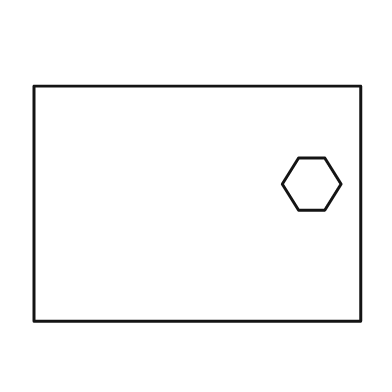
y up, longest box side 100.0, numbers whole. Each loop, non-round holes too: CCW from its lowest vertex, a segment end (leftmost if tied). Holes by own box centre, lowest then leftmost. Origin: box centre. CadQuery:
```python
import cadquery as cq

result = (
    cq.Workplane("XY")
    .moveTo(-50.0, -36.0)
    .lineTo(50.0, -36.0)
    .lineTo(50.0, 36.0)
    .lineTo(-50.0, 36.0)
    .close()
    .moveTo(31.0, -2.0)
    .lineTo(39.0, -2.0)
    .lineTo(44.0, 6.0)
    .lineTo(39.0, 14.0)
    .lineTo(31.0, 14.0)
    .lineTo(26.0, 6.0)
    .close()
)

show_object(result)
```